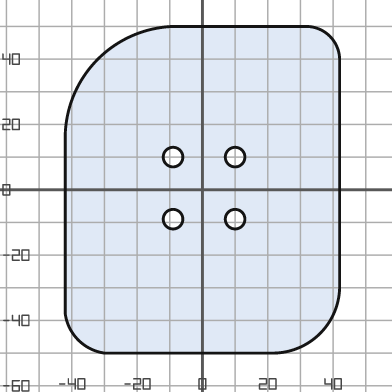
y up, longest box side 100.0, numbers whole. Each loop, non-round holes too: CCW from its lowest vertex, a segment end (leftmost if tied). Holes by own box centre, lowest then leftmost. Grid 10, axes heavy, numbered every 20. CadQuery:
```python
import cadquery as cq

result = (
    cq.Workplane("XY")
    .moveTo(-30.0, -50.0)
    .lineTo(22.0, -50.0)
    .threePointArc((36.0, -44.0), (42.0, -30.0))
    .lineTo(42.0, 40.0)
    .threePointArc((39.0, 47.0), (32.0, 50.0))
    .lineTo(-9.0, 50.0)
    .threePointArc((-32.0, 40.0), (-42.0, 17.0))
    .lineTo(-42.0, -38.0)
    .threePointArc((-38.0, -46.0), (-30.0, -50.0))
    .close()
    .moveTo(-9.0, -9.0)
    .circle(3.0)
    .moveTo(10.0, -9.0)
    .circle(3.0)
    .moveTo(-9.0, 10.0)
    .circle(3.0)
    .moveTo(10.0, 10.0)
    .circle(3.0)
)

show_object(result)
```